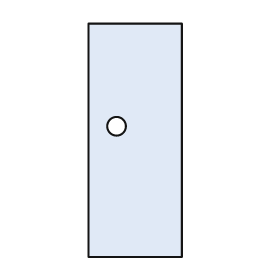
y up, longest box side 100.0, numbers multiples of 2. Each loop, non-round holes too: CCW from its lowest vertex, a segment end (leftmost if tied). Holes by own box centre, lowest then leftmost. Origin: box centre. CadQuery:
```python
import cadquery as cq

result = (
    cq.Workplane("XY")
    .moveTo(-20.0, -50.0)
    .lineTo(20.0, -50.0)
    .lineTo(20.0, 50.0)
    .lineTo(-20.0, 50.0)
    .close()
    .moveTo(-8.0, 6.0)
    .circle(4.0)
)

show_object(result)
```